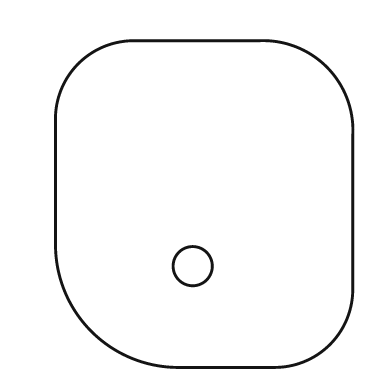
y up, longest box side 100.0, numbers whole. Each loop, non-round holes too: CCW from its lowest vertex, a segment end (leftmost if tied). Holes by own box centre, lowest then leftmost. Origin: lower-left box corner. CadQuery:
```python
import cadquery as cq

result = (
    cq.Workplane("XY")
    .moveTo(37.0, 0.0)
    .lineTo(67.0, 0.0)
    .threePointArc((84.0, 7.0), (91.0, 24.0))
    .lineTo(91.0, 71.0)
    .threePointArc((83.0, 92.0), (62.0, 100.0))
    .lineTo(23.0, 100.0)
    .threePointArc((7.0, 93.0), (0.0, 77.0))
    .lineTo(0.0, 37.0)
    .threePointArc((11.0, 11.0), (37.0, 0.0))
    .close()
    .moveTo(42.0, 31.0)
    .circle(6.0)
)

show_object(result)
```